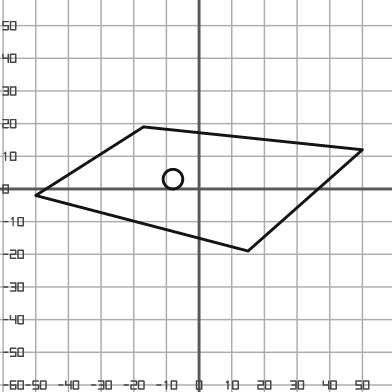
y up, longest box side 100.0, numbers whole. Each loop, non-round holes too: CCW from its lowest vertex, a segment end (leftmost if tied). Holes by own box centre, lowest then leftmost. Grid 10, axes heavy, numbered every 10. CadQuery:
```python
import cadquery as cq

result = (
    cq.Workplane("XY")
    .moveTo(15.0, -19.0)
    .lineTo(50.0, 12.0)
    .lineTo(-17.0, 19.0)
    .lineTo(-50.0, -2.0)
    .close()
    .moveTo(-8.0, 3.0)
    .circle(3.0)
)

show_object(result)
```